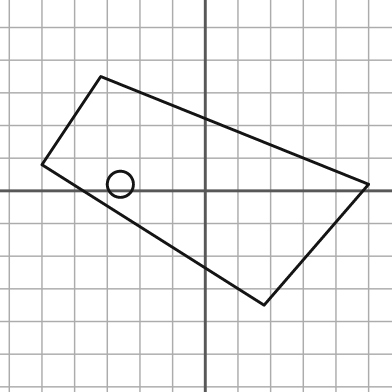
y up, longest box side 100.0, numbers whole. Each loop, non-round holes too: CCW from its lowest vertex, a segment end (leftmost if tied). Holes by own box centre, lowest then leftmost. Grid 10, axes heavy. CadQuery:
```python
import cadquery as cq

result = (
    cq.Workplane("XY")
    .moveTo(18.0, -35.0)
    .lineTo(50.0, 2.0)
    .lineTo(-32.0, 35.0)
    .lineTo(-50.0, 8.0)
    .close()
    .moveTo(-26.0, 2.0)
    .circle(4.0)
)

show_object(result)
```